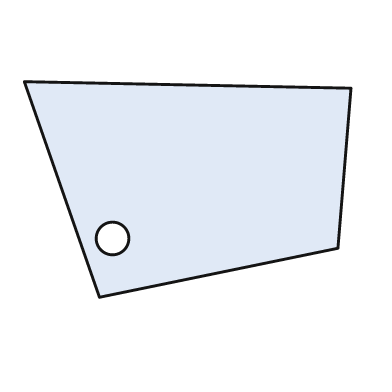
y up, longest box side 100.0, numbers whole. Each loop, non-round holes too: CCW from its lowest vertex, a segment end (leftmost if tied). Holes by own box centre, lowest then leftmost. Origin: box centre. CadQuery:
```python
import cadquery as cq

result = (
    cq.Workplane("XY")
    .moveTo(-27.0, -33.0)
    .lineTo(46.0, -18.0)
    .lineTo(50.0, 31.0)
    .lineTo(-50.0, 33.0)
    .close()
    .moveTo(-23.0, -15.0)
    .circle(5.0)
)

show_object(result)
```